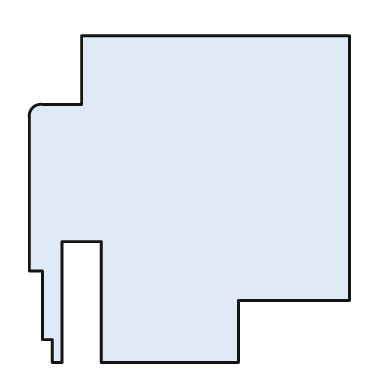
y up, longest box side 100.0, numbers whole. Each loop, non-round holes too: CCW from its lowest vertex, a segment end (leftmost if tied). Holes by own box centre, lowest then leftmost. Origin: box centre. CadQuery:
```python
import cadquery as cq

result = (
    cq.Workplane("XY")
    .moveTo(-42.0, -50.0)
    .lineTo(-39.0, -50.0)
    .lineTo(-39.0, -13.0)
    .lineTo(-27.0, -13.0)
    .lineTo(-27.0, -50.0)
    .lineTo(15.0, -50.0)
    .lineTo(15.0, -31.0)
    .lineTo(49.0, -31.0)
    .lineTo(49.0, 50.0)
    .lineTo(-33.0, 50.0)
    .lineTo(-33.0, 29.0)
    .lineTo(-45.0, 29.0)
    .threePointArc((-48.0, 28.0), (-49.0, 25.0))
    .lineTo(-49.0, -22.0)
    .lineTo(-45.0, -22.0)
    .lineTo(-45.0, -43.0)
    .lineTo(-42.0, -43.0)
    .close()
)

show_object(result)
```